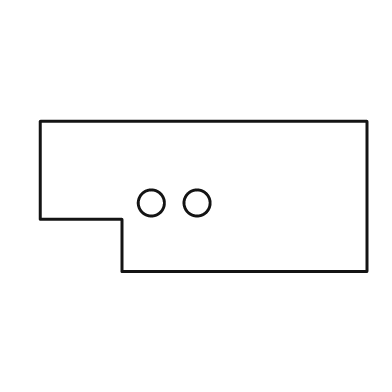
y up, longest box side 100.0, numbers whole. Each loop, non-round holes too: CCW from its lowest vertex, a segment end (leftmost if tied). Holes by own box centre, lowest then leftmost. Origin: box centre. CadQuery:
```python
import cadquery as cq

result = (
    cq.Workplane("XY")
    .moveTo(-25.0, -23.0)
    .lineTo(50.0, -23.0)
    .lineTo(50.0, 23.0)
    .lineTo(-50.0, 23.0)
    .lineTo(-50.0, -7.0)
    .lineTo(-25.0, -7.0)
    .close()
    .moveTo(-16.0, -2.0)
    .circle(4.0)
    .moveTo(-2.0, -2.0)
    .circle(4.0)
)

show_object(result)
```